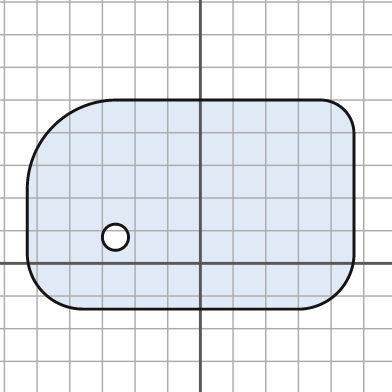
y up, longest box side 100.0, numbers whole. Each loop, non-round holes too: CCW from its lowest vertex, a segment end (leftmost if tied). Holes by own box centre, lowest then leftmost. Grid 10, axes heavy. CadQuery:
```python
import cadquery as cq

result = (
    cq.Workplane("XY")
    .moveTo(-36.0, -14.0)
    .lineTo(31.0, -14.0)
    .threePointArc((42.0, -9.0), (47.0, 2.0))
    .lineTo(47.0, 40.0)
    .threePointArc((44.0, 47.0), (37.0, 50.0))
    .lineTo(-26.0, 50.0)
    .threePointArc((-45.0, 42.0), (-53.0, 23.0))
    .lineTo(-53.0, 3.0)
    .threePointArc((-48.0, -9.0), (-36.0, -14.0))
    .close()
    .moveTo(-26.0, 8.0)
    .circle(4.0)
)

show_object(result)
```